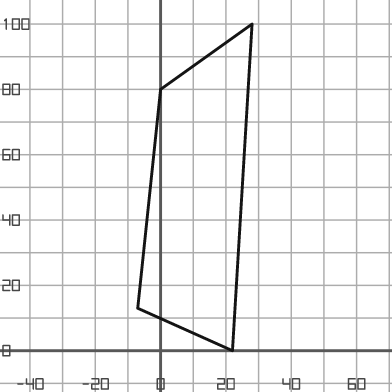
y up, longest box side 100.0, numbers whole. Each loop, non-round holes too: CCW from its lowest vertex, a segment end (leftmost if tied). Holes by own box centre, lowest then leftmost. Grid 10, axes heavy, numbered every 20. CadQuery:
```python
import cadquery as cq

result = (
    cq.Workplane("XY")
    .moveTo(22.0, 0.0)
    .lineTo(28.0, 100.0)
    .lineTo(0.0, 80.0)
    .lineTo(-7.0, 13.0)
    .close()
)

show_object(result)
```